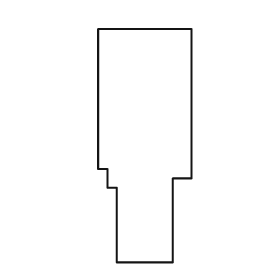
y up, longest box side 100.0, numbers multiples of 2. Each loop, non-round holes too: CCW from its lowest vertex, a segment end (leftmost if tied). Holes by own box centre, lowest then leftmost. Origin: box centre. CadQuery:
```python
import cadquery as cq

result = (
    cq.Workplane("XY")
    .moveTo(-12.0, -50.0)
    .lineTo(12.0, -50.0)
    .lineTo(12.0, -14.0)
    .lineTo(20.0, -14.0)
    .lineTo(20.0, 50.0)
    .lineTo(-20.0, 50.0)
    .lineTo(-20.0, -10.0)
    .lineTo(-16.0, -10.0)
    .lineTo(-16.0, -18.0)
    .lineTo(-12.0, -18.0)
    .close()
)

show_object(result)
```